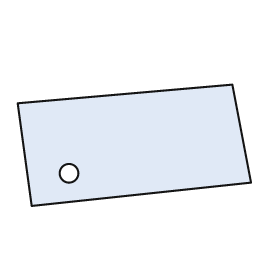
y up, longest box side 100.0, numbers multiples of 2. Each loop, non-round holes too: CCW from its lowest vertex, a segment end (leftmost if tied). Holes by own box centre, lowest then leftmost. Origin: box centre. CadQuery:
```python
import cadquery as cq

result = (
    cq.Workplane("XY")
    .moveTo(-44.0, -26.0)
    .lineTo(50.0, -16.0)
    .lineTo(42.0, 26.0)
    .lineTo(-50.0, 18.0)
    .close()
    .moveTo(-28.0, -12.0)
    .circle(4.0)
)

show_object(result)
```